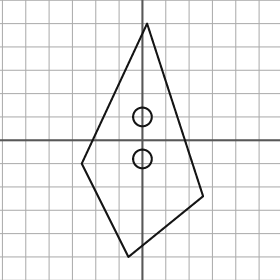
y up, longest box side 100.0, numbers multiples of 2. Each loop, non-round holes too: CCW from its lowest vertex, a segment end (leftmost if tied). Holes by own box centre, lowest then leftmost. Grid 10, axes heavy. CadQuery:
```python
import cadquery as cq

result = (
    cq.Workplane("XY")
    .moveTo(-6.0, -50.0)
    .lineTo(26.0, -24.0)
    .lineTo(2.0, 50.0)
    .lineTo(-26.0, -10.0)
    .close()
    .moveTo(0.0, -8.0)
    .circle(4.0)
    .moveTo(0.0, 10.0)
    .circle(4.0)
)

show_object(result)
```